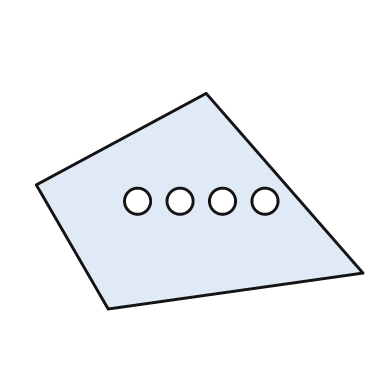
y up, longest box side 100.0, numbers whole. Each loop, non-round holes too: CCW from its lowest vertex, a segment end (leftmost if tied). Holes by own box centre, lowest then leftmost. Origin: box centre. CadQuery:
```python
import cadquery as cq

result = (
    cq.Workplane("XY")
    .moveTo(-28.0, -33.0)
    .lineTo(50.0, -22.0)
    .lineTo(2.0, 33.0)
    .lineTo(-50.0, 5.0)
    .close()
    .moveTo(-19.0, 0.0)
    .circle(4.0)
    .moveTo(-6.0, 0.0)
    .circle(4.0)
    .moveTo(7.0, 0.0)
    .circle(4.0)
    .moveTo(20.0, 0.0)
    .circle(4.0)
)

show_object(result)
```